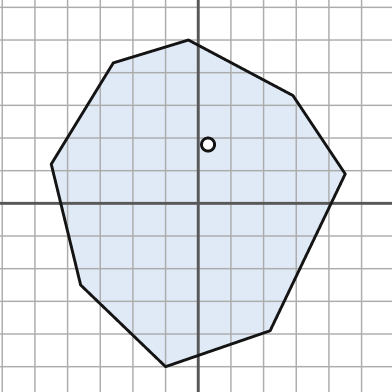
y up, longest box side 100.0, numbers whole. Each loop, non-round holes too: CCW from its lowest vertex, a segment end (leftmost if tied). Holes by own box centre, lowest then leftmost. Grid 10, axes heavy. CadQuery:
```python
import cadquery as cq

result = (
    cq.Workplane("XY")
    .moveTo(-10.0, -50.0)
    .lineTo(22.0, -39.0)
    .lineTo(45.0, 9.0)
    .lineTo(29.0, 33.0)
    .lineTo(-3.0, 50.0)
    .lineTo(-26.0, 43.0)
    .lineTo(-45.0, 12.0)
    .lineTo(-36.0, -25.0)
    .close()
    .moveTo(3.0, 18.0)
    .circle(2.0)
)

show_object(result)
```